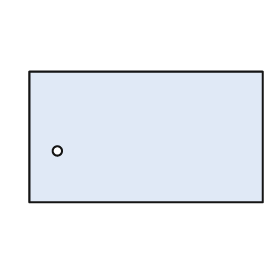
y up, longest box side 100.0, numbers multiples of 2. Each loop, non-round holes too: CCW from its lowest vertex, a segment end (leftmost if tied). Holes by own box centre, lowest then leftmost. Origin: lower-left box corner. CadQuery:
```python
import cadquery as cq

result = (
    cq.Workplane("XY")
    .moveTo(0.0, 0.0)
    .lineTo(100.0, 0.0)
    .lineTo(100.0, 56.0)
    .lineTo(0.0, 56.0)
    .close()
    .moveTo(12.0, 22.0)
    .circle(2.0)
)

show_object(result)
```